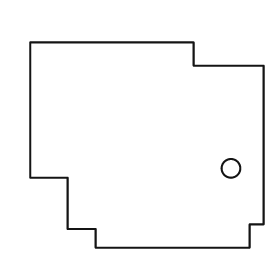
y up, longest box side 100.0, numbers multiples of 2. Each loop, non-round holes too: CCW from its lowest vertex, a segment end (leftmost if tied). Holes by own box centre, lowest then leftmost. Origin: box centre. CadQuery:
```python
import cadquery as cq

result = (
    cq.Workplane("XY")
    .moveTo(-22.0, -44.0)
    .lineTo(44.0, -44.0)
    .lineTo(44.0, -34.0)
    .lineTo(50.0, -34.0)
    .lineTo(50.0, 34.0)
    .lineTo(20.0, 34.0)
    .lineTo(20.0, 44.0)
    .lineTo(-50.0, 44.0)
    .lineTo(-50.0, -14.0)
    .lineTo(-34.0, -14.0)
    .lineTo(-34.0, -36.0)
    .lineTo(-22.0, -36.0)
    .close()
    .moveTo(36.0, -10.0)
    .circle(4.0)
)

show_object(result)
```